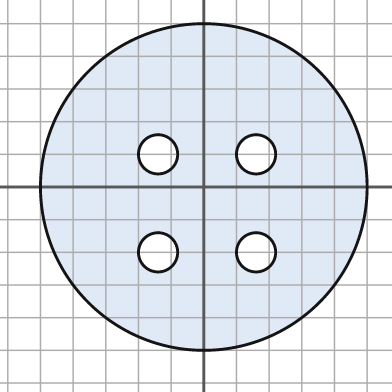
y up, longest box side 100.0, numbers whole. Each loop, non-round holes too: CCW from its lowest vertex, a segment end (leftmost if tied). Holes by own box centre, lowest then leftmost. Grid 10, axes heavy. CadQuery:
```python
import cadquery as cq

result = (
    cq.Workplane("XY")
    .moveTo(0.0, 0.0)
    .circle(50.0)
    .moveTo(-14.0, -20.0)
    .circle(6.0)
    .moveTo(16.0, -20.0)
    .circle(6.0)
    .moveTo(-14.0, 10.0)
    .circle(6.0)
    .moveTo(16.0, 10.0)
    .circle(6.0)
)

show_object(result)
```